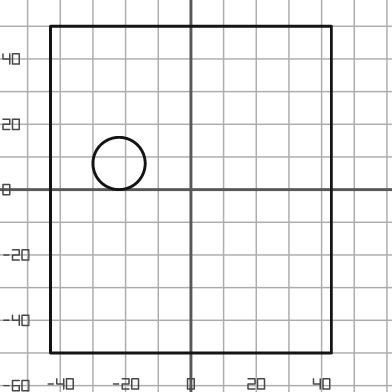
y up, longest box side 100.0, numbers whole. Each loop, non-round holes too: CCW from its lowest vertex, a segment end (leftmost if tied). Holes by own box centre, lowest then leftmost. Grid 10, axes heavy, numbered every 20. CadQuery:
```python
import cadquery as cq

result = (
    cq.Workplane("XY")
    .moveTo(-43.0, -50.0)
    .lineTo(43.0, -50.0)
    .lineTo(43.0, 50.0)
    .lineTo(-43.0, 50.0)
    .close()
    .moveTo(-22.0, 8.0)
    .circle(8.0)
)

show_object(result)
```